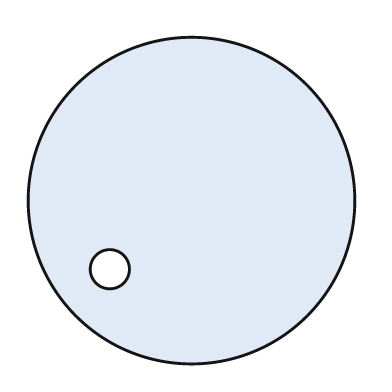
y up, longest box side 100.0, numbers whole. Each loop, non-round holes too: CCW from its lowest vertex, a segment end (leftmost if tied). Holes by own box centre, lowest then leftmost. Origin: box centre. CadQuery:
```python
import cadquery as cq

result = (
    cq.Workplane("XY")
    .moveTo(0.0, 0.0)
    .circle(50.0)
    .moveTo(-25.0, -21.0)
    .circle(6.0)
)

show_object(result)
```